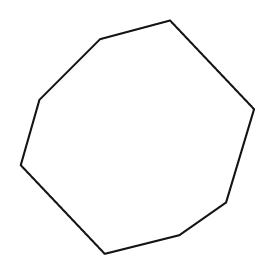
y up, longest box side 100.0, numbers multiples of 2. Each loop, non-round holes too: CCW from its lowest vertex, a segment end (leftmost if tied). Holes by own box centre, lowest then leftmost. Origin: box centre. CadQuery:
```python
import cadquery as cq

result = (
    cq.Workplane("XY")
    .moveTo(-14.0, -50.0)
    .lineTo(18.0, -42.0)
    .lineTo(38.0, -28.0)
    .lineTo(50.0, 12.0)
    .lineTo(14.0, 50.0)
    .lineTo(-16.0, 42.0)
    .lineTo(-42.0, 16.0)
    .lineTo(-50.0, -12.0)
    .close()
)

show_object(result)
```